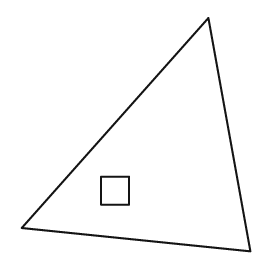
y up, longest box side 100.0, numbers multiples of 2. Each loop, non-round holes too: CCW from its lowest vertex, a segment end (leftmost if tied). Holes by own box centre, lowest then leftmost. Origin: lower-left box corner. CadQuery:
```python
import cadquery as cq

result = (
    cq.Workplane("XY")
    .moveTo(98.0, 0.0)
    .lineTo(80.0, 100.0)
    .lineTo(0.0, 10.0)
    .close()
    .moveTo(34.0, 20.0)
    .lineTo(46.0, 20.0)
    .lineTo(46.0, 32.0)
    .lineTo(34.0, 32.0)
    .close()
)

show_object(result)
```